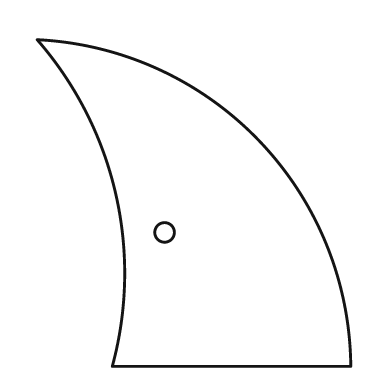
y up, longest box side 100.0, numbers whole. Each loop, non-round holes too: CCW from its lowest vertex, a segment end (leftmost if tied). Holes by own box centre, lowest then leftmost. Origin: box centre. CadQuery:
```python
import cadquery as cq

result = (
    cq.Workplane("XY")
    .moveTo(-25.0, -50.0)
    .lineTo(48.0, -50.0)
    .threePointArc((20.0, 19.0), (-48.0, 50.0))
    .threePointArc((-24.0, 3.0), (-25.0, -50.0))
    .close()
    .moveTo(-9.0, -9.0)
    .circle(3.0)
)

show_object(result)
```